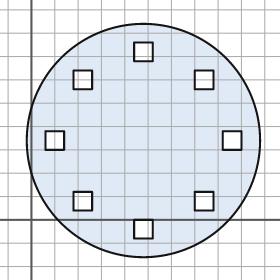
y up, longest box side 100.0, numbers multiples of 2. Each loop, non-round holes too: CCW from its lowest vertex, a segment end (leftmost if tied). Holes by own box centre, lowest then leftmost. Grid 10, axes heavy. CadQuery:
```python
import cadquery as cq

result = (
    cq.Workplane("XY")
    .moveTo(48.0, 34.0)
    .circle(50.0)
    .moveTo(44.0, -8.0)
    .lineTo(52.0, -8.0)
    .lineTo(52.0, 0.0)
    .lineTo(44.0, 0.0)
    .close()
    .moveTo(18.0, 4.0)
    .lineTo(26.0, 4.0)
    .lineTo(26.0, 12.0)
    .lineTo(18.0, 12.0)
    .close()
    .moveTo(70.0, 4.0)
    .lineTo(78.0, 4.0)
    .lineTo(78.0, 12.0)
    .lineTo(70.0, 12.0)
    .close()
    .moveTo(6.0, 30.0)
    .lineTo(14.0, 30.0)
    .lineTo(14.0, 38.0)
    .lineTo(6.0, 38.0)
    .close()
    .moveTo(82.0, 30.0)
    .lineTo(90.0, 30.0)
    .lineTo(90.0, 38.0)
    .lineTo(82.0, 38.0)
    .close()
    .moveTo(18.0, 56.0)
    .lineTo(26.0, 56.0)
    .lineTo(26.0, 64.0)
    .lineTo(18.0, 64.0)
    .close()
    .moveTo(70.0, 56.0)
    .lineTo(78.0, 56.0)
    .lineTo(78.0, 64.0)
    .lineTo(70.0, 64.0)
    .close()
    .moveTo(44.0, 68.0)
    .lineTo(52.0, 68.0)
    .lineTo(52.0, 76.0)
    .lineTo(44.0, 76.0)
    .close()
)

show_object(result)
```